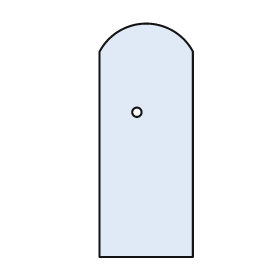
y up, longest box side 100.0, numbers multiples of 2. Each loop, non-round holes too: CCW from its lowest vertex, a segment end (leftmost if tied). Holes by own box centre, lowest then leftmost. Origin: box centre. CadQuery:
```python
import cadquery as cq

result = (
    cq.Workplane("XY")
    .moveTo(-20.0, -50.0)
    .lineTo(20.0, -50.0)
    .lineTo(20.0, 38.0)
    .threePointArc((0.0, 50.0), (-20.0, 38.0))
    .close()
    .moveTo(-4.0, 12.0)
    .circle(2.0)
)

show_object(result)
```